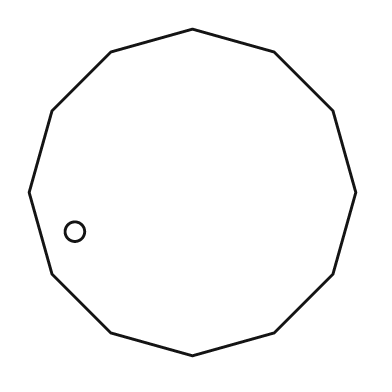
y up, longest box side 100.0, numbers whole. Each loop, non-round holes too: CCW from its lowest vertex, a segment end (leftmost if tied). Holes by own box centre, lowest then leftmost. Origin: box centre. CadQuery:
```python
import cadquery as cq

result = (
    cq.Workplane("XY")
    .moveTo(0.0, -50.0)
    .lineTo(25.0, -43.0)
    .lineTo(43.0, -25.0)
    .lineTo(50.0, 0.0)
    .lineTo(43.0, 25.0)
    .lineTo(25.0, 43.0)
    .lineTo(0.0, 50.0)
    .lineTo(-25.0, 43.0)
    .lineTo(-43.0, 25.0)
    .lineTo(-50.0, 0.0)
    .lineTo(-43.0, -25.0)
    .lineTo(-25.0, -43.0)
    .close()
    .moveTo(-36.0, -12.0)
    .circle(3.0)
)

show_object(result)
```